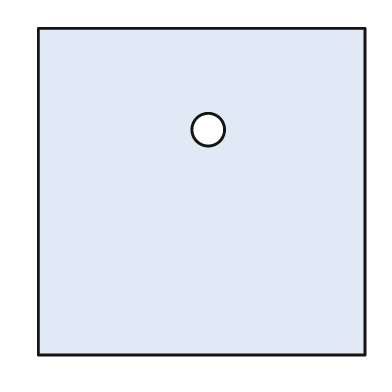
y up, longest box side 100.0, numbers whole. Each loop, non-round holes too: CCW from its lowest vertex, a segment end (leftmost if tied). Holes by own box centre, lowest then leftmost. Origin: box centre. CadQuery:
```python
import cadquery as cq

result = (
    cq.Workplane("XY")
    .moveTo(-50.0, -50.0)
    .lineTo(50.0, -50.0)
    .lineTo(50.0, 50.0)
    .lineTo(-50.0, 50.0)
    .close()
    .moveTo(2.0, 19.0)
    .circle(5.0)
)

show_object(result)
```